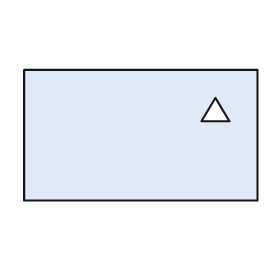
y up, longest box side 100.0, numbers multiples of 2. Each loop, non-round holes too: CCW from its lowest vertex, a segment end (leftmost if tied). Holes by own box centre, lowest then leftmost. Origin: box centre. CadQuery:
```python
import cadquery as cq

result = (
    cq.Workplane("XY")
    .moveTo(-50.0, -28.0)
    .lineTo(50.0, -28.0)
    .lineTo(50.0, 28.0)
    .lineTo(-50.0, 28.0)
    .close()
    .moveTo(26.0, 6.0)
    .lineTo(38.0, 6.0)
    .lineTo(32.0, 16.0)
    .close()
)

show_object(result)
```